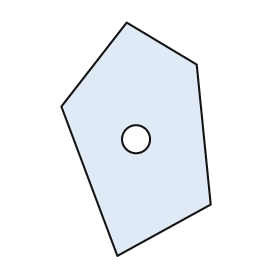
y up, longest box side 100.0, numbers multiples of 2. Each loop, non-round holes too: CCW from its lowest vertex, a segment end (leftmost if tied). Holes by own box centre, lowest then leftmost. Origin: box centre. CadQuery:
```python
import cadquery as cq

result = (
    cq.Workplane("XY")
    .moveTo(-8.0, -50.0)
    .lineTo(32.0, -28.0)
    .lineTo(26.0, 32.0)
    .lineTo(-4.0, 50.0)
    .lineTo(-32.0, 14.0)
    .close()
    .moveTo(0.0, 0.0)
    .circle(6.0)
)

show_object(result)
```